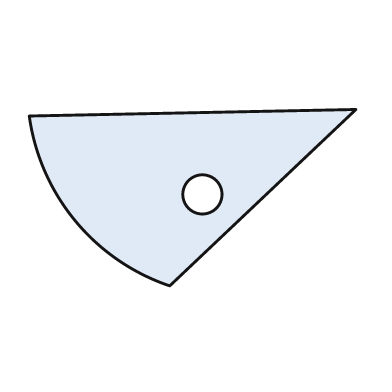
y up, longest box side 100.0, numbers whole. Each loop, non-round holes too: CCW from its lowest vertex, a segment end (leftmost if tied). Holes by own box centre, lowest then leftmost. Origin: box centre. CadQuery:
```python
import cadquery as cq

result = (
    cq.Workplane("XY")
    .moveTo(-7.0, -27.0)
    .lineTo(50.0, 27.0)
    .lineTo(-50.0, 25.0)
    .threePointArc((-36.0, -7.0), (-7.0, -27.0))
    .close()
    .moveTo(3.0, 1.0)
    .circle(6.0)
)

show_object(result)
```